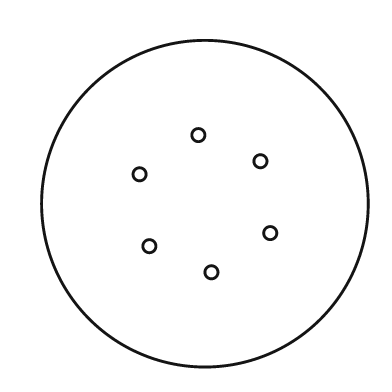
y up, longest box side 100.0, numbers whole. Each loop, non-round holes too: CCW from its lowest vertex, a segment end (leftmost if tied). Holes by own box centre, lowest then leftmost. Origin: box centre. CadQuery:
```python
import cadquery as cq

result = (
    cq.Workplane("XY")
    .moveTo(0.0, 0.0)
    .circle(50.0)
    .moveTo(2.0, -21.0)
    .circle(2.0)
    .moveTo(-17.0, -13.0)
    .circle(2.0)
    .moveTo(20.0, -9.0)
    .circle(2.0)
    .moveTo(-20.0, 9.0)
    .circle(2.0)
    .moveTo(17.0, 13.0)
    .circle(2.0)
    .moveTo(-2.0, 21.0)
    .circle(2.0)
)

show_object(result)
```